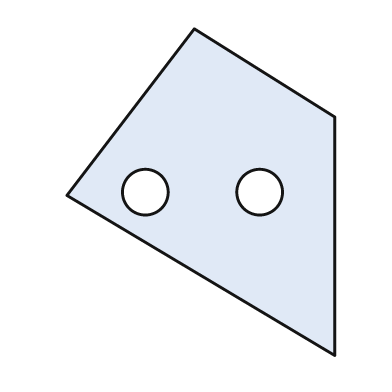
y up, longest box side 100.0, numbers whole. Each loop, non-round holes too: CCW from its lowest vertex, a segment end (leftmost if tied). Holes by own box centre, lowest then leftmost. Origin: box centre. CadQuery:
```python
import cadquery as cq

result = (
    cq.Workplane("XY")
    .moveTo(41.0, -50.0)
    .lineTo(41.0, 23.0)
    .lineTo(-2.0, 50.0)
    .lineTo(-41.0, -1.0)
    .close()
    .moveTo(-17.0, 0.0)
    .circle(7.0)
    .moveTo(18.0, 0.0)
    .circle(7.0)
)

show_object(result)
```